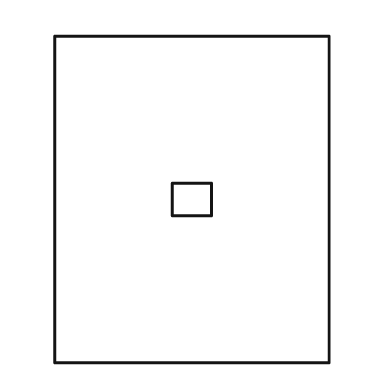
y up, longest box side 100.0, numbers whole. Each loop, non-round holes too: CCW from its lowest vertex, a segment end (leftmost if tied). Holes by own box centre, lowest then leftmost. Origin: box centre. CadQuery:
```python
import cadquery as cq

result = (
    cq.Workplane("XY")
    .moveTo(-42.0, -50.0)
    .lineTo(42.0, -50.0)
    .lineTo(42.0, 50.0)
    .lineTo(-42.0, 50.0)
    .close()
    .moveTo(-6.0, -5.0)
    .lineTo(6.0, -5.0)
    .lineTo(6.0, 5.0)
    .lineTo(-6.0, 5.0)
    .close()
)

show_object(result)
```